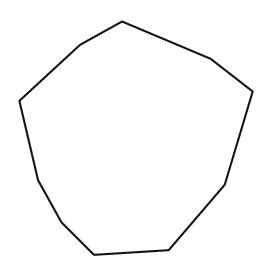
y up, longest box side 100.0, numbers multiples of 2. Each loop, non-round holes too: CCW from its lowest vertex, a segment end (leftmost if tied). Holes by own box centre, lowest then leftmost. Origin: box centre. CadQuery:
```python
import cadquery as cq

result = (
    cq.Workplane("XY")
    .moveTo(-18.0, -50.0)
    .lineTo(14.0, -48.0)
    .lineTo(38.0, -20.0)
    .lineTo(50.0, 20.0)
    .lineTo(32.0, 34.0)
    .lineTo(-6.0, 50.0)
    .lineTo(-24.0, 40.0)
    .lineTo(-50.0, 16.0)
    .lineTo(-42.0, -18.0)
    .lineTo(-32.0, -36.0)
    .close()
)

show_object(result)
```